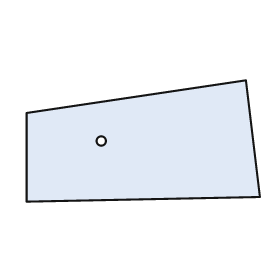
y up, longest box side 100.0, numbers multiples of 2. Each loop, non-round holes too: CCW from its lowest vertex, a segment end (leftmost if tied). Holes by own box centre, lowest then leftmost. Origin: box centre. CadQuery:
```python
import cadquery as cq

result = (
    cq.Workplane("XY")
    .moveTo(-50.0, -26.0)
    .lineTo(50.0, -24.0)
    .lineTo(44.0, 26.0)
    .lineTo(-50.0, 12.0)
    .close()
    .moveTo(-18.0, 0.0)
    .circle(2.0)
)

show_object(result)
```